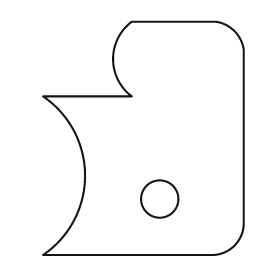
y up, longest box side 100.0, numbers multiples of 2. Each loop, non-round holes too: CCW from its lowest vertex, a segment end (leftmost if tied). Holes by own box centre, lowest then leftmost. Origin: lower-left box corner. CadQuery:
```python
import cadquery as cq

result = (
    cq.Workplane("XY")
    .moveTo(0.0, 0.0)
    .lineTo(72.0, 0.0)
    .threePointArc((82.0, 4.0), (86.0, 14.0))
    .lineTo(86.0, 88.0)
    .threePointArc((82.0, 96.0), (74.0, 100.0))
    .lineTo(38.0, 100.0)
    .threePointArc((30.0, 84.0), (38.0, 68.0))
    .lineTo(0.0, 68.0)
    .threePointArc((18.0, 34.0), (0.0, 0.0))
    .close()
    .moveTo(50.0, 24.0)
    .circle(8.0)
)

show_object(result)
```